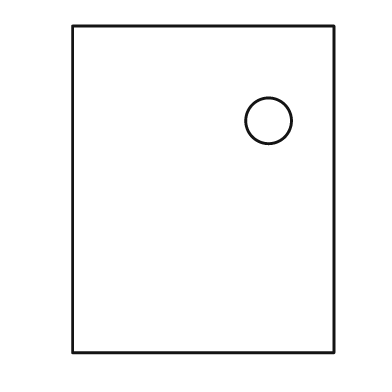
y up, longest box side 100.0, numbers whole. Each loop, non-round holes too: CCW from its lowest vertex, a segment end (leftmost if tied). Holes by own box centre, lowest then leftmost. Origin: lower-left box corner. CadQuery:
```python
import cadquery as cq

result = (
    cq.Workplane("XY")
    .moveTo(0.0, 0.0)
    .lineTo(80.0, 0.0)
    .lineTo(80.0, 100.0)
    .lineTo(0.0, 100.0)
    .close()
    .moveTo(60.0, 71.0)
    .circle(7.0)
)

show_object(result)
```